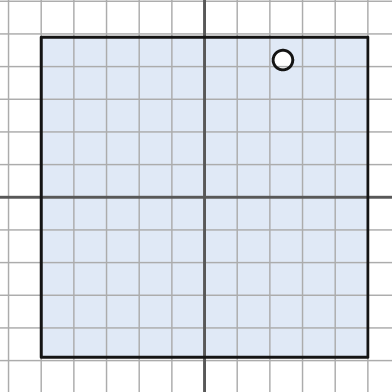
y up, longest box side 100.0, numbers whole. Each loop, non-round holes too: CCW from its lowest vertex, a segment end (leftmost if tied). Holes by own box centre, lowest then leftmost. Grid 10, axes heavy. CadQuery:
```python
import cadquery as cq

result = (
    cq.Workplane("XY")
    .moveTo(-50.0, -49.0)
    .lineTo(50.0, -49.0)
    .lineTo(50.0, 49.0)
    .lineTo(-50.0, 49.0)
    .close()
    .moveTo(24.0, 42.0)
    .circle(3.0)
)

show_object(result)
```